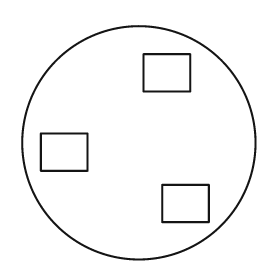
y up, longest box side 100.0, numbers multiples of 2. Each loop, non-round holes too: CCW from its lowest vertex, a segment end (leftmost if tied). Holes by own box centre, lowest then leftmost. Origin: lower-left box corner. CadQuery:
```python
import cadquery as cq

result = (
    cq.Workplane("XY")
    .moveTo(50.0, 50.0)
    .circle(50.0)
    .moveTo(60.0, 16.0)
    .lineTo(80.0, 16.0)
    .lineTo(80.0, 32.0)
    .lineTo(60.0, 32.0)
    .close()
    .moveTo(8.0, 38.0)
    .lineTo(28.0, 38.0)
    .lineTo(28.0, 54.0)
    .lineTo(8.0, 54.0)
    .close()
    .moveTo(52.0, 72.0)
    .lineTo(72.0, 72.0)
    .lineTo(72.0, 88.0)
    .lineTo(52.0, 88.0)
    .close()
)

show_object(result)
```